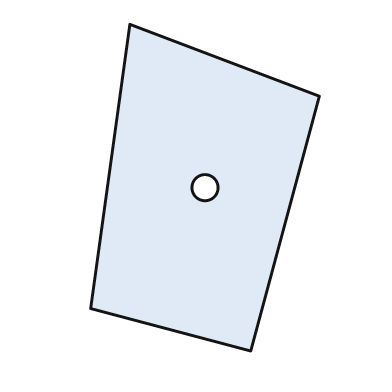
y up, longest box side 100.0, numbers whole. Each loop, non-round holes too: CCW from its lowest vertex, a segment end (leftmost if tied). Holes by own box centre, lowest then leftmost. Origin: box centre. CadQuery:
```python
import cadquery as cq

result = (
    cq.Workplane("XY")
    .moveTo(14.0, -50.0)
    .lineTo(35.0, 28.0)
    .lineTo(-23.0, 50.0)
    .lineTo(-35.0, -37.0)
    .close()
    .moveTo(0.0, 0.0)
    .circle(4.0)
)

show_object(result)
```